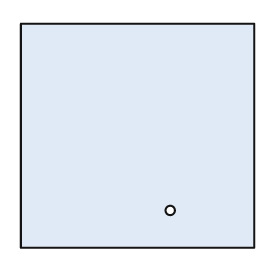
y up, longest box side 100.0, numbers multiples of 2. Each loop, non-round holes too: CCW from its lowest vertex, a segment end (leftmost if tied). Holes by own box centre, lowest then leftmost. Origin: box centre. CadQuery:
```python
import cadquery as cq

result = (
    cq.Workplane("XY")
    .moveTo(-50.0, -48.0)
    .lineTo(50.0, -48.0)
    .lineTo(50.0, 48.0)
    .lineTo(-50.0, 48.0)
    .close()
    .moveTo(14.0, -32.0)
    .circle(2.0)
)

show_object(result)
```